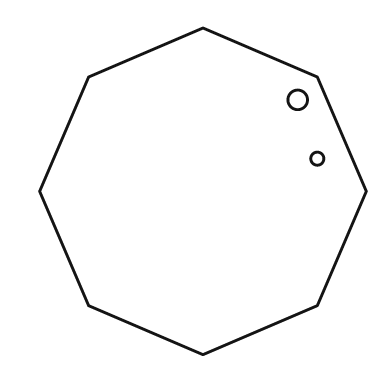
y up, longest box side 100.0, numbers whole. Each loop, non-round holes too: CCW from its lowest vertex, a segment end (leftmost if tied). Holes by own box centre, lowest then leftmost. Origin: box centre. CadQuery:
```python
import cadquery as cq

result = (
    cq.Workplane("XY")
    .moveTo(0.0, -50.0)
    .lineTo(35.0, -35.0)
    .lineTo(50.0, 0.0)
    .lineTo(35.0, 35.0)
    .lineTo(0.0, 50.0)
    .lineTo(-35.0, 35.0)
    .lineTo(-50.0, 0.0)
    .lineTo(-35.0, -35.0)
    .close()
    .moveTo(35.0, 10.0)
    .circle(2.0)
    .moveTo(29.0, 28.0)
    .circle(3.0)
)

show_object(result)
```